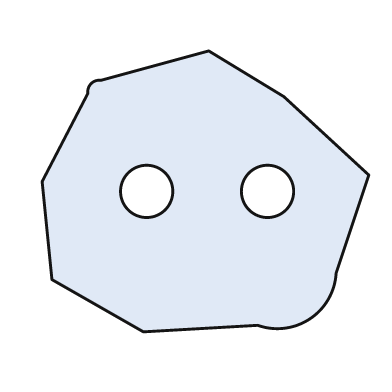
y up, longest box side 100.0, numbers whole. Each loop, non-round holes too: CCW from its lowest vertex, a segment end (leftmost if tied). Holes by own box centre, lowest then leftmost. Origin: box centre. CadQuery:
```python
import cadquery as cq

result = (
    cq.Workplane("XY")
    .moveTo(-19.0, -43.0)
    .lineTo(16.0, -41.0)
    .threePointArc((32.0, -39.0), (40.0, -25.0))
    .lineTo(50.0, 5.0)
    .lineTo(24.0, 29.0)
    .lineTo(1.0, 43.0)
    .lineTo(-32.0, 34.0)
    .threePointArc((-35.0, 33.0), (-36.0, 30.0))
    .lineTo(-50.0, 3.0)
    .lineTo(-47.0, -27.0)
    .close()
    .moveTo(-18.0, 0.0)
    .circle(8.0)
    .moveTo(19.0, 0.0)
    .circle(8.0)
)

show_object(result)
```